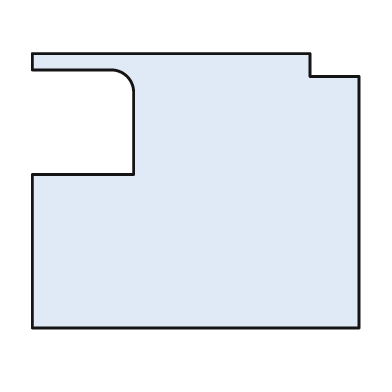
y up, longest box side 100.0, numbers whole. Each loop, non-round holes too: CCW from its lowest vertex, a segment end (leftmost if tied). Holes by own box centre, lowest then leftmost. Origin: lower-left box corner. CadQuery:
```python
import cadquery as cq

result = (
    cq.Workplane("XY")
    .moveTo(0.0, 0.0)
    .lineTo(100.0, 0.0)
    .lineTo(100.0, 77.0)
    .lineTo(85.0, 77.0)
    .lineTo(85.0, 84.0)
    .lineTo(0.0, 84.0)
    .lineTo(0.0, 79.0)
    .lineTo(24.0, 79.0)
    .threePointArc((29.0, 77.0), (31.0, 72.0))
    .lineTo(31.0, 47.0)
    .lineTo(0.0, 47.0)
    .close()
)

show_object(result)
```